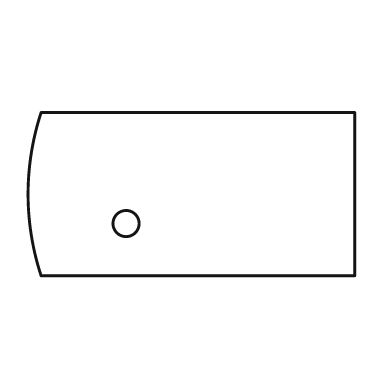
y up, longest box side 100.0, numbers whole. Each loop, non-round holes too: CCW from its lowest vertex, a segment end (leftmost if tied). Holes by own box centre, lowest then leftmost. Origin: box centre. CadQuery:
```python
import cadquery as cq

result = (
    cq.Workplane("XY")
    .moveTo(-46.0, -25.0)
    .lineTo(50.0, -25.0)
    .lineTo(50.0, 25.0)
    .lineTo(-46.0, 25.0)
    .threePointArc((-50.0, 0.0), (-46.0, -25.0))
    .close()
    .moveTo(-20.0, -9.0)
    .circle(4.0)
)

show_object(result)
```